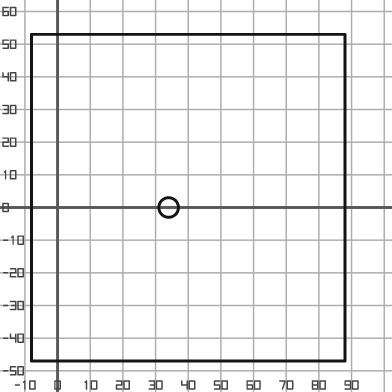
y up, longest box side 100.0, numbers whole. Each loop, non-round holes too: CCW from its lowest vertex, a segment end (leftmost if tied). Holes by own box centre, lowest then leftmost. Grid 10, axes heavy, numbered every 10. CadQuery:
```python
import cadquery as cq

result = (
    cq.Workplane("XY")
    .moveTo(-8.0, -47.0)
    .lineTo(88.0, -47.0)
    .lineTo(88.0, 53.0)
    .lineTo(-8.0, 53.0)
    .close()
    .moveTo(34.0, 0.0)
    .circle(3.0)
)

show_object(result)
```